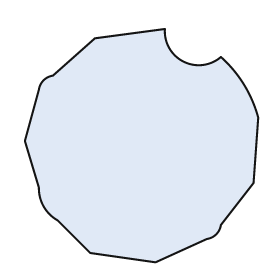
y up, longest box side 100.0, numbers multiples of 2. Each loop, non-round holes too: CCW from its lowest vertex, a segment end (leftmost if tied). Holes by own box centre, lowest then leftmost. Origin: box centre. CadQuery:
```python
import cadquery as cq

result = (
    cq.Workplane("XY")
    .moveTo(6.0, -50.0)
    .lineTo(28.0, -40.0)
    .threePointArc((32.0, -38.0), (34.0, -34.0))
    .lineTo(48.0, -16.0)
    .lineTo(50.0, 12.0)
    .threePointArc((44.0, 26.0), (34.0, 38.0))
    .threePointArc((18.0, 36.0), (10.0, 50.0))
    .lineTo(-20.0, 46.0)
    .lineTo(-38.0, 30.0)
    .threePointArc((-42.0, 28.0), (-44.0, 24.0))
    .lineTo(-50.0, 2.0)
    .lineTo(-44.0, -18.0)
    .threePointArc((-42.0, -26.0), (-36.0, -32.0))
    .lineTo(-22.0, -46.0)
    .close()
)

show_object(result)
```